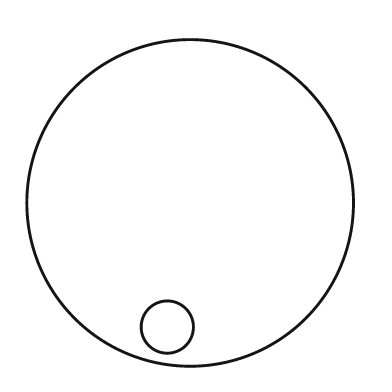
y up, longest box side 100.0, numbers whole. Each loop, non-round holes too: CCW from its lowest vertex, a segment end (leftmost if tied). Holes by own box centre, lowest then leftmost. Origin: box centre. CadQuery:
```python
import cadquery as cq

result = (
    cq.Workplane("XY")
    .moveTo(0.0, 0.0)
    .circle(50.0)
    .moveTo(-7.0, -38.0)
    .circle(8.0)
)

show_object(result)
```